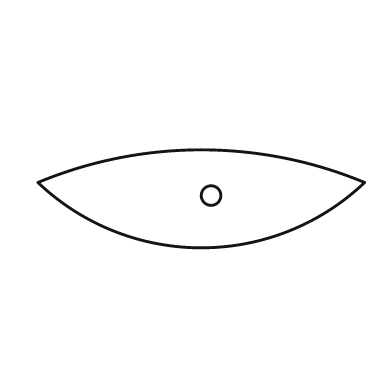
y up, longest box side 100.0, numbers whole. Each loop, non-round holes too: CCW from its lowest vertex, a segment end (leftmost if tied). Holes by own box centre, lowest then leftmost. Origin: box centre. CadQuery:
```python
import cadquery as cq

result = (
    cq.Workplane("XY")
    .moveTo(-50.0, 5.0)
    .threePointArc((0.0, -15.0), (50.0, 5.0))
    .threePointArc((0.0, 15.0), (-50.0, 5.0))
    .close()
    .moveTo(3.0, 1.0)
    .circle(3.0)
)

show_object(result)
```